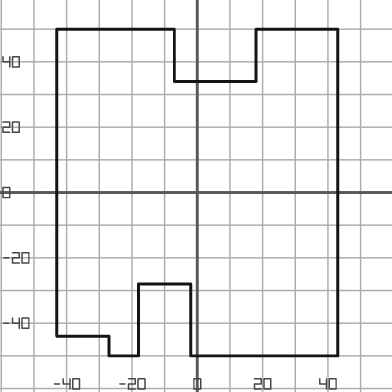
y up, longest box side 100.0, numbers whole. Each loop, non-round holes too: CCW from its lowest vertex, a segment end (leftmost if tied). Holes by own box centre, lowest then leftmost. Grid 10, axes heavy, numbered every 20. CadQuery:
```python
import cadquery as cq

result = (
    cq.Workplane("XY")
    .moveTo(-27.0, -50.0)
    .lineTo(-18.0, -50.0)
    .lineTo(-18.0, -28.0)
    .lineTo(-2.0, -28.0)
    .lineTo(-2.0, -50.0)
    .lineTo(43.0, -50.0)
    .lineTo(43.0, 50.0)
    .lineTo(18.0, 50.0)
    .lineTo(18.0, 34.0)
    .lineTo(-7.0, 34.0)
    .lineTo(-7.0, 50.0)
    .lineTo(-43.0, 50.0)
    .lineTo(-43.0, -44.0)
    .lineTo(-27.0, -44.0)
    .close()
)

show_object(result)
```